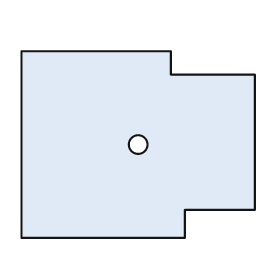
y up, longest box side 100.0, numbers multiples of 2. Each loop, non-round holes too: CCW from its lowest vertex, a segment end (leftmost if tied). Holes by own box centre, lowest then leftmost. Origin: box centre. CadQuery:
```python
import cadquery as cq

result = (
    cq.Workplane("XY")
    .moveTo(-50.0, -40.0)
    .lineTo(20.0, -40.0)
    .lineTo(20.0, -28.0)
    .lineTo(50.0, -28.0)
    .lineTo(50.0, 30.0)
    .lineTo(14.0, 30.0)
    .lineTo(14.0, 40.0)
    .lineTo(-50.0, 40.0)
    .close()
    .moveTo(0.0, 0.0)
    .circle(4.0)
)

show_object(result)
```